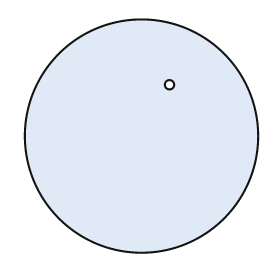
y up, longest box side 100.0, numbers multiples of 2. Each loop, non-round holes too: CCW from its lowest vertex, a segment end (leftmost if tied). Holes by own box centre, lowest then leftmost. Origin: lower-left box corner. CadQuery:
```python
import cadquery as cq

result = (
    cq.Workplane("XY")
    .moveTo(50.0, 50.0)
    .circle(50.0)
    .moveTo(62.0, 72.0)
    .circle(2.0)
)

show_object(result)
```